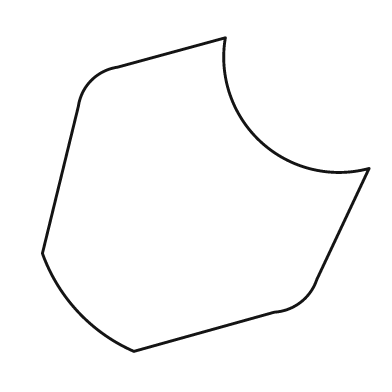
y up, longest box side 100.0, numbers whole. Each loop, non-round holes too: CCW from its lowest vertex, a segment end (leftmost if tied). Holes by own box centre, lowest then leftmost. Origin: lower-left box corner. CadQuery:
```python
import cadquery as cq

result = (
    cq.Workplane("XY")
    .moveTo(28.0, 0.0)
    .lineTo(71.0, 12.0)
    .threePointArc((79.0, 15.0), (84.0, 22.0))
    .lineTo(100.0, 56.0)
    .threePointArc((67.0, 64.0), (56.0, 96.0))
    .lineTo(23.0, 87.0)
    .threePointArc((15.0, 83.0), (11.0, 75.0))
    .lineTo(0.0, 30.0)
    .threePointArc((11.0, 12.0), (28.0, 0.0))
    .close()
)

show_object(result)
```